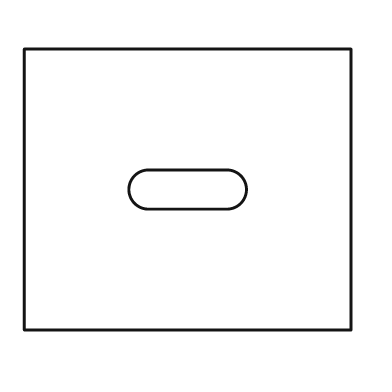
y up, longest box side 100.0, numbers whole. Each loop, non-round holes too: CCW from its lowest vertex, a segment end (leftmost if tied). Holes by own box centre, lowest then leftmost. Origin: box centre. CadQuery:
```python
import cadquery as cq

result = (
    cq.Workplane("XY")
    .moveTo(-50.0, -43.0)
    .lineTo(50.0, -43.0)
    .lineTo(50.0, 43.0)
    .lineTo(-50.0, 43.0)
    .close()
    .moveTo(-12.0, -6.0)
    .lineTo(12.0, -6.0)
    .threePointArc((18.0, 0.0), (12.0, 6.0))
    .lineTo(-12.0, 6.0)
    .threePointArc((-18.0, 0.0), (-12.0, -6.0))
    .close()
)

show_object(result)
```